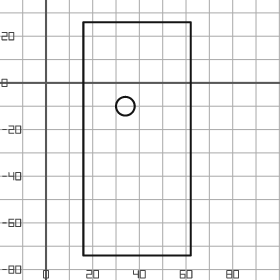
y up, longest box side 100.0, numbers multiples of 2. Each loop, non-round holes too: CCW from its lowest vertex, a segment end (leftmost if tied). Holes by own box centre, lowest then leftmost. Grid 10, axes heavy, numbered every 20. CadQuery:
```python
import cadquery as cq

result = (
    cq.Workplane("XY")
    .moveTo(16.0, -74.0)
    .lineTo(62.0, -74.0)
    .lineTo(62.0, 26.0)
    .lineTo(16.0, 26.0)
    .close()
    .moveTo(34.0, -10.0)
    .circle(4.0)
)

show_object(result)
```